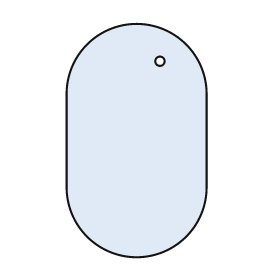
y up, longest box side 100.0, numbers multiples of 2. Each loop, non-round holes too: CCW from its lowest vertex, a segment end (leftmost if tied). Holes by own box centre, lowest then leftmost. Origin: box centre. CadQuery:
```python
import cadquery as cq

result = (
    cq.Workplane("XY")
    .moveTo(-30.0, -20.0)
    .threePointArc((0.0, -50.0), (30.0, -20.0))
    .lineTo(30.0, 20.0)
    .threePointArc((0.0, 50.0), (-30.0, 20.0))
    .close()
    .moveTo(10.0, 34.0)
    .circle(2.0)
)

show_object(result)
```